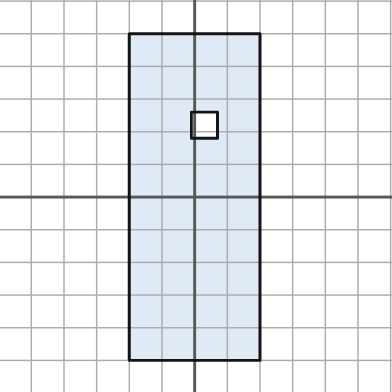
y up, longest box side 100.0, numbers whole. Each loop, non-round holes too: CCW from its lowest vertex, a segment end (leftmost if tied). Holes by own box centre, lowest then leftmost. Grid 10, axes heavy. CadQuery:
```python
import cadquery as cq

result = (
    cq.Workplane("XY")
    .moveTo(-20.0, -50.0)
    .lineTo(20.0, -50.0)
    .lineTo(20.0, 50.0)
    .lineTo(-20.0, 50.0)
    .close()
    .moveTo(-1.0, 18.0)
    .lineTo(7.0, 18.0)
    .lineTo(7.0, 26.0)
    .lineTo(-1.0, 26.0)
    .close()
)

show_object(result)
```